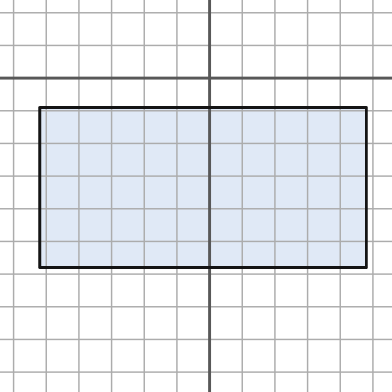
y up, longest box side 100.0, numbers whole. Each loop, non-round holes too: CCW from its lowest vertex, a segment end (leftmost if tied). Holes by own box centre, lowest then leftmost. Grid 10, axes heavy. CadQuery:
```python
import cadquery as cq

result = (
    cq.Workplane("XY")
    .moveTo(-52.0, -58.0)
    .lineTo(48.0, -58.0)
    .lineTo(48.0, -9.0)
    .lineTo(-52.0, -9.0)
    .close()
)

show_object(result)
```